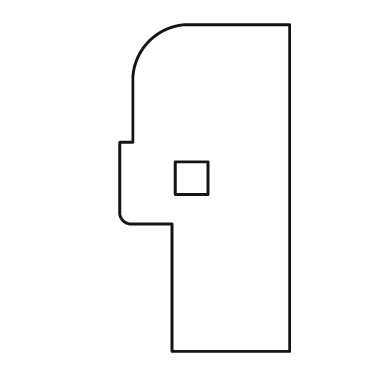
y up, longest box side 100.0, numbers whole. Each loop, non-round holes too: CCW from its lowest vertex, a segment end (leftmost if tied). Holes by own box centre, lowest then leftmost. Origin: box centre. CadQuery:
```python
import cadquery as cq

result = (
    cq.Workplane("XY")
    .moveTo(-10.0, -50.0)
    .lineTo(26.0, -50.0)
    .lineTo(26.0, 50.0)
    .lineTo(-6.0, 50.0)
    .threePointArc((-17.0, 45.0), (-22.0, 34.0))
    .lineTo(-22.0, 14.0)
    .lineTo(-26.0, 14.0)
    .lineTo(-26.0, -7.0)
    .threePointArc((-25.0, -10.0), (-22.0, -11.0))
    .lineTo(-10.0, -11.0)
    .close()
    .moveTo(-9.0, -2.0)
    .lineTo(1.0, -2.0)
    .lineTo(1.0, 8.0)
    .lineTo(-9.0, 8.0)
    .close()
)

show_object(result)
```